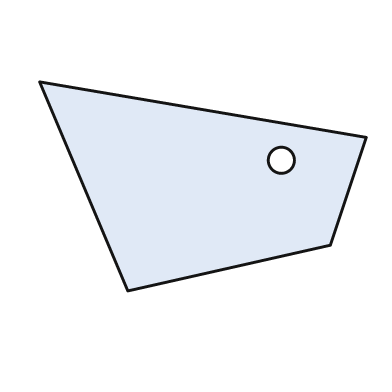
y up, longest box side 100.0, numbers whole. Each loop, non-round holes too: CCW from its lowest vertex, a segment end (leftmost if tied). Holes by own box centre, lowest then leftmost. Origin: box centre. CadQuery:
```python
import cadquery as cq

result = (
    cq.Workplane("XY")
    .moveTo(-23.0, -32.0)
    .lineTo(39.0, -18.0)
    .lineTo(50.0, 15.0)
    .lineTo(-50.0, 32.0)
    .close()
    .moveTo(24.0, 8.0)
    .circle(4.0)
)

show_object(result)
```